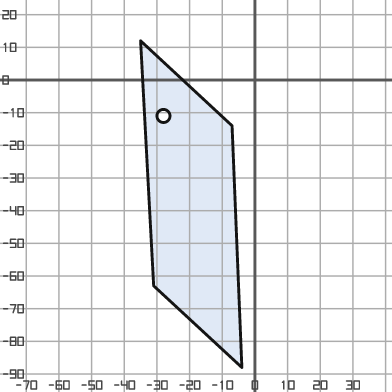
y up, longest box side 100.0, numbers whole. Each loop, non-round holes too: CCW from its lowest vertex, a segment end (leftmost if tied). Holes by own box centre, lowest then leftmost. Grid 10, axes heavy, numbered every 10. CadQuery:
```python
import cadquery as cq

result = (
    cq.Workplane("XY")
    .moveTo(-4.0, -88.0)
    .lineTo(-7.0, -14.0)
    .lineTo(-35.0, 12.0)
    .lineTo(-31.0, -63.0)
    .close()
    .moveTo(-28.0, -11.0)
    .circle(2.0)
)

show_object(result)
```